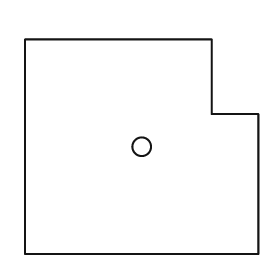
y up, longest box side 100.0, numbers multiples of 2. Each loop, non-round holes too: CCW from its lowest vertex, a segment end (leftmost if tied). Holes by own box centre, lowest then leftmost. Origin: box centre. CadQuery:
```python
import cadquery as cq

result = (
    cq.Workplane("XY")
    .moveTo(-50.0, -46.0)
    .lineTo(50.0, -46.0)
    .lineTo(50.0, 14.0)
    .lineTo(30.0, 14.0)
    .lineTo(30.0, 46.0)
    .lineTo(-50.0, 46.0)
    .close()
    .moveTo(0.0, 0.0)
    .circle(4.0)
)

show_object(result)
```